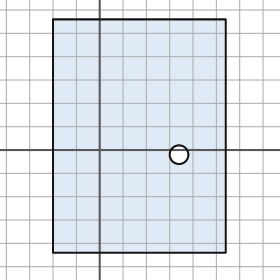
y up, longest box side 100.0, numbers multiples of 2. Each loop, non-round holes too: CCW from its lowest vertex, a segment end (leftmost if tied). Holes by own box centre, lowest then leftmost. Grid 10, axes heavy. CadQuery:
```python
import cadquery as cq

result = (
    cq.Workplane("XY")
    .moveTo(-20.0, -44.0)
    .lineTo(54.0, -44.0)
    .lineTo(54.0, 56.0)
    .lineTo(-20.0, 56.0)
    .close()
    .moveTo(34.0, -2.0)
    .circle(4.0)
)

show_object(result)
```